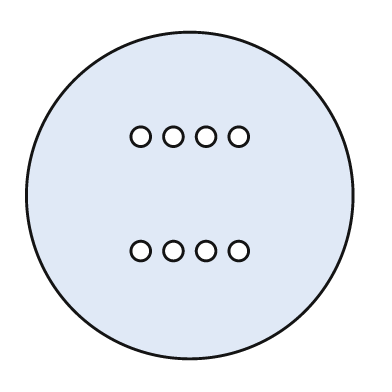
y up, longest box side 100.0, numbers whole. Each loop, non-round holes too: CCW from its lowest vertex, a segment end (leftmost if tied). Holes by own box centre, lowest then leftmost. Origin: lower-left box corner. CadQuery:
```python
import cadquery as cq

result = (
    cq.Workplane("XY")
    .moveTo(50.0, 50.0)
    .circle(50.0)
    .moveTo(35.0, 33.0)
    .circle(3.0)
    .moveTo(45.0, 33.0)
    .circle(3.0)
    .moveTo(55.0, 33.0)
    .circle(3.0)
    .moveTo(65.0, 33.0)
    .circle(3.0)
    .moveTo(35.0, 68.0)
    .circle(3.0)
    .moveTo(45.0, 68.0)
    .circle(3.0)
    .moveTo(55.0, 68.0)
    .circle(3.0)
    .moveTo(65.0, 68.0)
    .circle(3.0)
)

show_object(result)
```